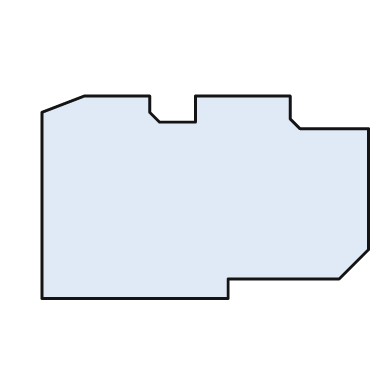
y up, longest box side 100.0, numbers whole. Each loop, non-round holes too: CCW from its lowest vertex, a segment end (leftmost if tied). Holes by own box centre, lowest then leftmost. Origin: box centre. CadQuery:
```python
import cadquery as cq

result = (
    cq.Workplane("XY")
    .moveTo(-50.0, -31.0)
    .lineTo(7.0, -31.0)
    .lineTo(7.0, -25.0)
    .lineTo(41.0, -25.0)
    .lineTo(50.0, -16.0)
    .lineTo(50.0, 21.0)
    .lineTo(29.0, 21.0)
    .lineTo(26.0, 24.0)
    .lineTo(26.0, 31.0)
    .lineTo(-3.0, 31.0)
    .lineTo(-3.0, 23.0)
    .lineTo(-14.0, 23.0)
    .lineTo(-17.0, 26.0)
    .lineTo(-17.0, 31.0)
    .lineTo(-37.0, 31.0)
    .lineTo(-50.0, 26.0)
    .close()
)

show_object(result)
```